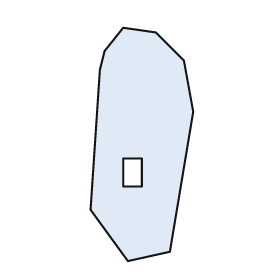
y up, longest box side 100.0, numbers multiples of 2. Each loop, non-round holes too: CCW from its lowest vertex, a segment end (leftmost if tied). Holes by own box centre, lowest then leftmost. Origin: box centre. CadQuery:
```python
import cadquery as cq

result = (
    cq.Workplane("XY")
    .moveTo(-6.0, -50.0)
    .lineTo(12.0, -46.0)
    .lineTo(22.0, 14.0)
    .lineTo(18.0, 36.0)
    .lineTo(6.0, 48.0)
    .lineTo(-8.0, 50.0)
    .lineTo(-16.0, 40.0)
    .lineTo(-18.0, 32.0)
    .lineTo(-22.0, -28.0)
    .close()
    .moveTo(-8.0, -18.0)
    .lineTo(0.0, -18.0)
    .lineTo(0.0, -6.0)
    .lineTo(-8.0, -6.0)
    .close()
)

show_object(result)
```